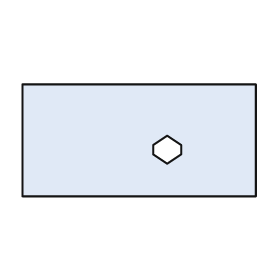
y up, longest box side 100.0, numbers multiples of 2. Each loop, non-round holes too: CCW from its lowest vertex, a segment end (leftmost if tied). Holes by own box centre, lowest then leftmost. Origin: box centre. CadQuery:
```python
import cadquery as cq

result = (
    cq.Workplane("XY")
    .moveTo(-50.0, -24.0)
    .lineTo(50.0, -24.0)
    .lineTo(50.0, 24.0)
    .lineTo(-50.0, 24.0)
    .close()
    .moveTo(12.0, -10.0)
    .lineTo(18.0, -6.0)
    .lineTo(18.0, -2.0)
    .lineTo(12.0, 2.0)
    .lineTo(6.0, -2.0)
    .lineTo(6.0, -6.0)
    .close()
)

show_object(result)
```